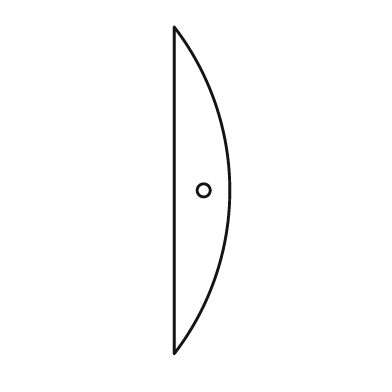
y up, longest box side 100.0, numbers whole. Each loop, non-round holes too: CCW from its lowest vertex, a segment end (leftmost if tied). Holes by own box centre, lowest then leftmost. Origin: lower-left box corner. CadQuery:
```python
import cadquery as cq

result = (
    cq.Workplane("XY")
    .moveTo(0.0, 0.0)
    .threePointArc((17.0, 50.0), (0.0, 100.0))
    .close()
    .moveTo(9.0, 50.0)
    .circle(2.0)
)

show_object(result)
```